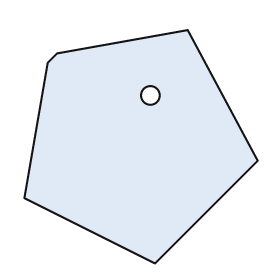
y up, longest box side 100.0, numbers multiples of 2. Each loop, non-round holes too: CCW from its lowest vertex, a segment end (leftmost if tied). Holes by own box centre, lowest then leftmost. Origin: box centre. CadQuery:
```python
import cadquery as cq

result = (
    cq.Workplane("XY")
    .moveTo(6.0, -50.0)
    .lineTo(50.0, -6.0)
    .lineTo(20.0, 50.0)
    .lineTo(-36.0, 40.0)
    .lineTo(-40.0, 36.0)
    .lineTo(-50.0, -22.0)
    .close()
    .moveTo(4.0, 22.0)
    .circle(4.0)
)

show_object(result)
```